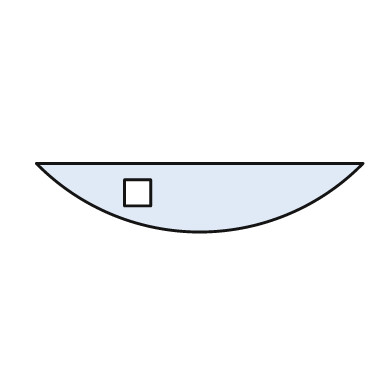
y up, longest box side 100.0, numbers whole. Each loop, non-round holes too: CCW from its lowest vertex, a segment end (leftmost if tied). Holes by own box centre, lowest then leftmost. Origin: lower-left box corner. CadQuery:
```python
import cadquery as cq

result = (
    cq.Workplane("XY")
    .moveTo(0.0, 21.0)
    .threePointArc((50.0, 0.0), (100.0, 21.0))
    .close()
    .moveTo(27.0, 8.0)
    .lineTo(35.0, 8.0)
    .lineTo(35.0, 16.0)
    .lineTo(27.0, 16.0)
    .close()
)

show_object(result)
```